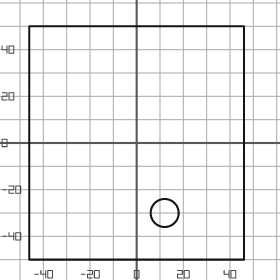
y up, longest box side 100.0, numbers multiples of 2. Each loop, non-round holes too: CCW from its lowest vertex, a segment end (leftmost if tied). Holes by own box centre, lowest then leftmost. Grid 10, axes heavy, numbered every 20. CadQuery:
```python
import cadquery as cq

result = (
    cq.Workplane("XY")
    .moveTo(-46.0, -50.0)
    .lineTo(46.0, -50.0)
    .lineTo(46.0, 50.0)
    .lineTo(-46.0, 50.0)
    .close()
    .moveTo(12.0, -30.0)
    .circle(6.0)
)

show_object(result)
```